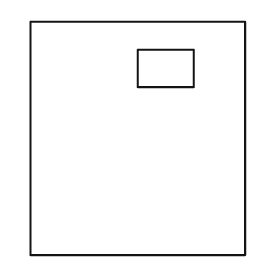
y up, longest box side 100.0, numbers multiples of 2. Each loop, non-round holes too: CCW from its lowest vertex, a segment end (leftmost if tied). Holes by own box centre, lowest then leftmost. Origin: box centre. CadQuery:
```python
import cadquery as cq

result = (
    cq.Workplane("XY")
    .moveTo(-46.0, -50.0)
    .lineTo(46.0, -50.0)
    .lineTo(46.0, 50.0)
    .lineTo(-46.0, 50.0)
    .close()
    .moveTo(0.0, 22.0)
    .lineTo(24.0, 22.0)
    .lineTo(24.0, 38.0)
    .lineTo(0.0, 38.0)
    .close()
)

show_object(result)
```